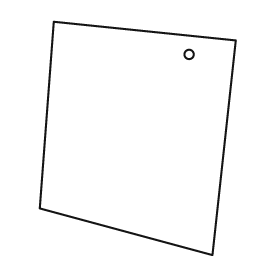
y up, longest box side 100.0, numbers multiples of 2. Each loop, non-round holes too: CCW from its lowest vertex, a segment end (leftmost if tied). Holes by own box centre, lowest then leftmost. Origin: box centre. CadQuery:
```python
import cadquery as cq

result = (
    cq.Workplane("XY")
    .moveTo(32.0, -50.0)
    .lineTo(42.0, 42.0)
    .lineTo(-36.0, 50.0)
    .lineTo(-42.0, -30.0)
    .close()
    .moveTo(22.0, 36.0)
    .circle(2.0)
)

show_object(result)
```